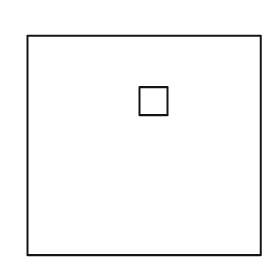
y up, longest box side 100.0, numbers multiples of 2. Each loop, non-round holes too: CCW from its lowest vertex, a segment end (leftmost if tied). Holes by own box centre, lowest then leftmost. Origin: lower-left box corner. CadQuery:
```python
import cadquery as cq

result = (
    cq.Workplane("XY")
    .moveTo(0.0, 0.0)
    .lineTo(100.0, 0.0)
    .lineTo(100.0, 94.0)
    .lineTo(0.0, 94.0)
    .close()
    .moveTo(48.0, 60.0)
    .lineTo(60.0, 60.0)
    .lineTo(60.0, 72.0)
    .lineTo(48.0, 72.0)
    .close()
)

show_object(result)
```